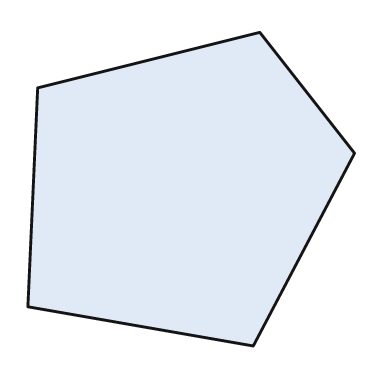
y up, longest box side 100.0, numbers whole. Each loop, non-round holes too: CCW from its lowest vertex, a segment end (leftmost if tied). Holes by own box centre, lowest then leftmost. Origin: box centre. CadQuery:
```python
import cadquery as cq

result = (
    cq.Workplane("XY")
    .moveTo(19.0, -48.0)
    .lineTo(50.0, 11.0)
    .lineTo(21.0, 48.0)
    .lineTo(-47.0, 31.0)
    .lineTo(-50.0, -36.0)
    .close()
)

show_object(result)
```